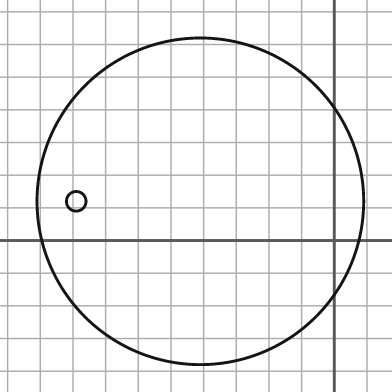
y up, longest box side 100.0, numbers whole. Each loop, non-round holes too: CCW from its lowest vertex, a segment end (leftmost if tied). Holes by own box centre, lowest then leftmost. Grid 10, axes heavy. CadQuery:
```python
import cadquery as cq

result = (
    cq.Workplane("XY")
    .moveTo(-41.0, 12.0)
    .circle(50.0)
    .moveTo(-79.0, 12.0)
    .circle(3.0)
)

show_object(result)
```